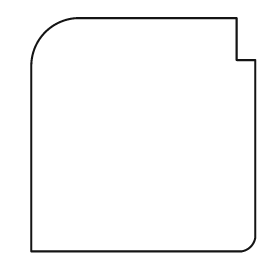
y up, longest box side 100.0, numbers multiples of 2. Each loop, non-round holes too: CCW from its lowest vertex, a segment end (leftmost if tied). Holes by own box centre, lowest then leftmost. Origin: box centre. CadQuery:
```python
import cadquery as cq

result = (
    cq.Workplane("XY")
    .moveTo(-48.0, -50.0)
    .lineTo(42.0, -50.0)
    .threePointArc((46.0, -48.0), (48.0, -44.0))
    .lineTo(48.0, 32.0)
    .lineTo(40.0, 32.0)
    .lineTo(40.0, 50.0)
    .lineTo(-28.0, 50.0)
    .threePointArc((-42.0, 44.0), (-48.0, 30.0))
    .close()
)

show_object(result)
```